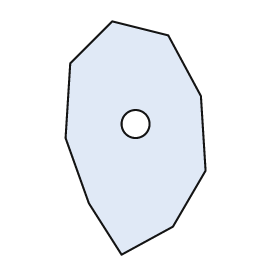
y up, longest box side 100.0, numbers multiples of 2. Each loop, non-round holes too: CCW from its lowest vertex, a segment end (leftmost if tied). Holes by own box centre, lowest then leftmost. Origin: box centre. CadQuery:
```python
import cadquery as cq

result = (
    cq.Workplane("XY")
    .moveTo(-6.0, -50.0)
    .lineTo(16.0, -38.0)
    .lineTo(30.0, -14.0)
    .lineTo(28.0, 18.0)
    .lineTo(14.0, 44.0)
    .lineTo(-10.0, 50.0)
    .lineTo(-28.0, 32.0)
    .lineTo(-30.0, 0.0)
    .lineTo(-20.0, -28.0)
    .close()
    .moveTo(0.0, 6.0)
    .circle(6.0)
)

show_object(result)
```